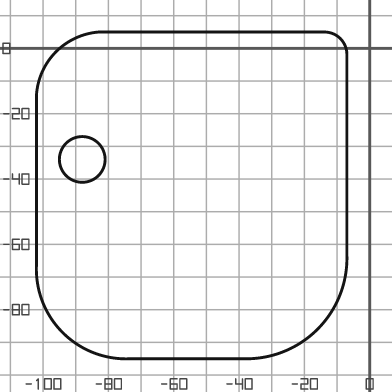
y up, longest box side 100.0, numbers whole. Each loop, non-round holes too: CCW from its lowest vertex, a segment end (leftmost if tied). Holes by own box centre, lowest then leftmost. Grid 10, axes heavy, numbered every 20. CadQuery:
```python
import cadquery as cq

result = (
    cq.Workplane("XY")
    .moveTo(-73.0, -95.0)
    .lineTo(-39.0, -95.0)
    .threePointArc((-16.0, -86.0), (-7.0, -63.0))
    .lineTo(-7.0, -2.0)
    .threePointArc((-9.0, 3.0), (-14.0, 5.0))
    .lineTo(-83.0, 5.0)
    .threePointArc((-96.0, -1.0), (-102.0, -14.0))
    .lineTo(-102.0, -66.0)
    .threePointArc((-94.0, -87.0), (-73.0, -95.0))
    .close()
    .moveTo(-88.0, -34.0)
    .circle(7.0)
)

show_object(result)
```